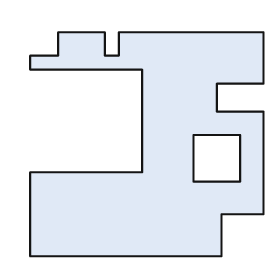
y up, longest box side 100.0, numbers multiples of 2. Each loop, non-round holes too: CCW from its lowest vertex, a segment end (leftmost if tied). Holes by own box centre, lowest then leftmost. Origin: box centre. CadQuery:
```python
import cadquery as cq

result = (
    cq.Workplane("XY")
    .moveTo(-50.0, -48.0)
    .lineTo(32.0, -48.0)
    .lineTo(32.0, -30.0)
    .lineTo(50.0, -30.0)
    .lineTo(50.0, 14.0)
    .lineTo(30.0, 14.0)
    .lineTo(30.0, 26.0)
    .lineTo(50.0, 26.0)
    .lineTo(50.0, 48.0)
    .lineTo(-12.0, 48.0)
    .lineTo(-12.0, 38.0)
    .lineTo(-18.0, 38.0)
    .lineTo(-18.0, 48.0)
    .lineTo(-38.0, 48.0)
    .lineTo(-38.0, 38.0)
    .lineTo(-50.0, 38.0)
    .lineTo(-50.0, 32.0)
    .lineTo(-2.0, 32.0)
    .lineTo(-2.0, -12.0)
    .lineTo(-50.0, -12.0)
    .close()
    .moveTo(20.0, -16.0)
    .lineTo(40.0, -16.0)
    .lineTo(40.0, 4.0)
    .lineTo(20.0, 4.0)
    .close()
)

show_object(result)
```